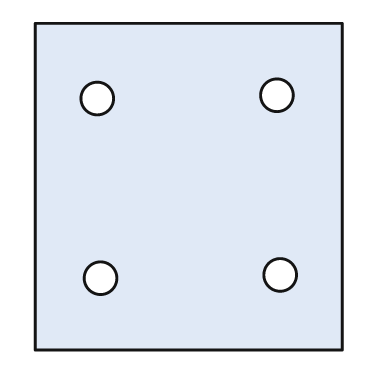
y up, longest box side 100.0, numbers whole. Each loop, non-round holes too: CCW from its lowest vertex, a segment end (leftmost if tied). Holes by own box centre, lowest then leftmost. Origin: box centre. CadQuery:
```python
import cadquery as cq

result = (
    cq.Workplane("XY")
    .moveTo(-47.0, -50.0)
    .lineTo(47.0, -50.0)
    .lineTo(47.0, 50.0)
    .lineTo(-47.0, 50.0)
    .close()
    .moveTo(-27.0, -28.0)
    .circle(5.0)
    .moveTo(28.0, -27.0)
    .circle(5.0)
    .moveTo(-28.0, 27.0)
    .circle(5.0)
    .moveTo(27.0, 28.0)
    .circle(5.0)
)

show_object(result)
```